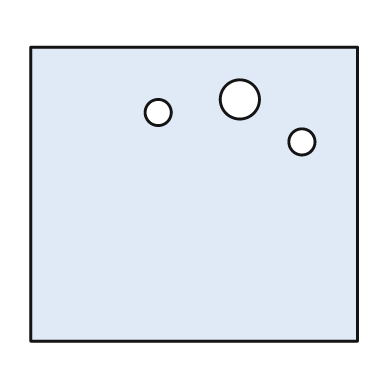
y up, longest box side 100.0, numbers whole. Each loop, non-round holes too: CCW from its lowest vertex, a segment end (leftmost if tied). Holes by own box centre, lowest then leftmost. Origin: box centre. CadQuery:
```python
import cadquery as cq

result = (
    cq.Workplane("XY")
    .moveTo(-50.0, -45.0)
    .lineTo(50.0, -45.0)
    .lineTo(50.0, 45.0)
    .lineTo(-50.0, 45.0)
    .close()
    .moveTo(33.0, 16.0)
    .circle(4.0)
    .moveTo(-11.0, 25.0)
    .circle(4.0)
    .moveTo(14.0, 29.0)
    .circle(6.0)
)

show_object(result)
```